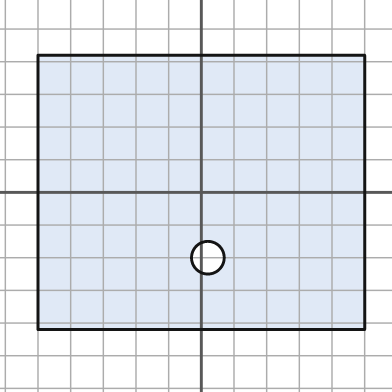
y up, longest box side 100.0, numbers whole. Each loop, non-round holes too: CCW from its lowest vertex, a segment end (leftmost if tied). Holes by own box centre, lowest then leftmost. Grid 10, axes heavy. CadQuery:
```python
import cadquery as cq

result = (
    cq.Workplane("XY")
    .moveTo(-50.0, -42.0)
    .lineTo(50.0, -42.0)
    .lineTo(50.0, 42.0)
    .lineTo(-50.0, 42.0)
    .close()
    .moveTo(2.0, -20.0)
    .circle(5.0)
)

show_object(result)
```